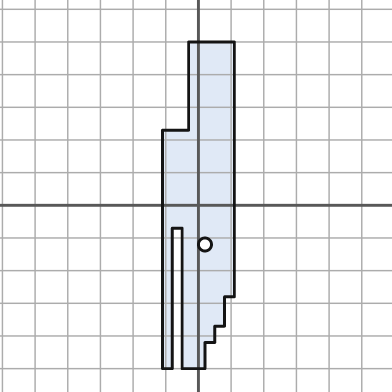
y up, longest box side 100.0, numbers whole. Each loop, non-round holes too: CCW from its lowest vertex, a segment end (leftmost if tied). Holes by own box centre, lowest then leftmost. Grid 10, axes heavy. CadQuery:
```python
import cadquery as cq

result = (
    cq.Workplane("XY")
    .moveTo(-11.0, -50.0)
    .lineTo(-8.0, -50.0)
    .lineTo(-8.0, -7.0)
    .lineTo(-5.0, -7.0)
    .lineTo(-5.0, -50.0)
    .lineTo(2.0, -50.0)
    .lineTo(2.0, -42.0)
    .lineTo(5.0, -42.0)
    .lineTo(5.0, -37.0)
    .lineTo(8.0, -37.0)
    .lineTo(8.0, -28.0)
    .lineTo(11.0, -28.0)
    .lineTo(11.0, 50.0)
    .lineTo(-3.0, 50.0)
    .lineTo(-3.0, 23.0)
    .lineTo(-11.0, 23.0)
    .close()
    .moveTo(2.0, -12.0)
    .circle(2.0)
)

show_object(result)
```